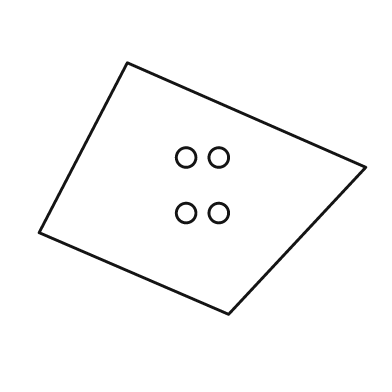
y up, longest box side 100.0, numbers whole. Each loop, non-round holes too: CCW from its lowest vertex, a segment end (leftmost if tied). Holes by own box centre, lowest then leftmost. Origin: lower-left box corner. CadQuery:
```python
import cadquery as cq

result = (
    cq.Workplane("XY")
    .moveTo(58.0, 0.0)
    .lineTo(100.0, 45.0)
    .lineTo(27.0, 77.0)
    .lineTo(0.0, 25.0)
    .close()
    .moveTo(45.0, 31.0)
    .circle(3.0)
    .moveTo(55.0, 31.0)
    .circle(3.0)
    .moveTo(45.0, 48.0)
    .circle(3.0)
    .moveTo(55.0, 48.0)
    .circle(3.0)
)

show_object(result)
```